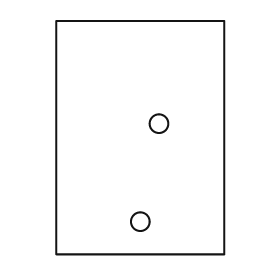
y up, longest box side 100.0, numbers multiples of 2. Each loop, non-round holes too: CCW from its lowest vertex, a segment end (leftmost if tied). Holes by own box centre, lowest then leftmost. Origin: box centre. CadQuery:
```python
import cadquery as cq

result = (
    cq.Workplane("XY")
    .moveTo(-36.0, -50.0)
    .lineTo(36.0, -50.0)
    .lineTo(36.0, 50.0)
    .lineTo(-36.0, 50.0)
    .close()
    .moveTo(0.0, -36.0)
    .circle(4.0)
    .moveTo(8.0, 6.0)
    .circle(4.0)
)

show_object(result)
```